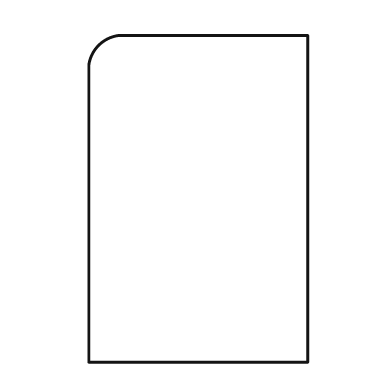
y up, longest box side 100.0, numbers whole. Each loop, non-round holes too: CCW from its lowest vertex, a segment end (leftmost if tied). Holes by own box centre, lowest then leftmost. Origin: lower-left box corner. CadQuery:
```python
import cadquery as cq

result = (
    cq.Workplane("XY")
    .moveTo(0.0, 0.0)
    .lineTo(67.0, 0.0)
    .lineTo(67.0, 100.0)
    .lineTo(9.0, 100.0)
    .threePointArc((3.0, 97.0), (0.0, 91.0))
    .close()
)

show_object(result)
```